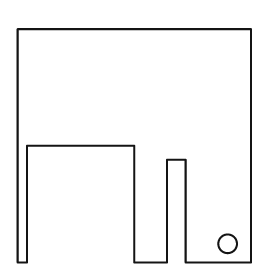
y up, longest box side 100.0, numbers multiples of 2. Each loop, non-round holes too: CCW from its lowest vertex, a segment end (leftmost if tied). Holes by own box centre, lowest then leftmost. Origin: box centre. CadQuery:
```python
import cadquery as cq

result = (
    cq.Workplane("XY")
    .moveTo(-50.0, -50.0)
    .lineTo(-46.0, -50.0)
    .lineTo(-46.0, 0.0)
    .lineTo(0.0, 0.0)
    .lineTo(0.0, -50.0)
    .lineTo(14.0, -50.0)
    .lineTo(14.0, -6.0)
    .lineTo(22.0, -6.0)
    .lineTo(22.0, -50.0)
    .lineTo(50.0, -50.0)
    .lineTo(50.0, 50.0)
    .lineTo(-50.0, 50.0)
    .close()
    .moveTo(40.0, -42.0)
    .circle(4.0)
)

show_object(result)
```